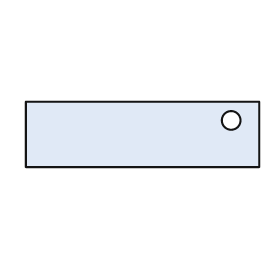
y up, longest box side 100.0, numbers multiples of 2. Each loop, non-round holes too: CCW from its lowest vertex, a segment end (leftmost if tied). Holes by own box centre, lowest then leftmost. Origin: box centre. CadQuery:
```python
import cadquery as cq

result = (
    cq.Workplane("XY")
    .moveTo(-50.0, -14.0)
    .lineTo(50.0, -14.0)
    .lineTo(50.0, 14.0)
    .lineTo(-50.0, 14.0)
    .close()
    .moveTo(38.0, 6.0)
    .circle(4.0)
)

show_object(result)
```